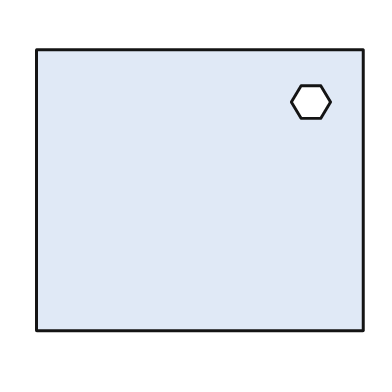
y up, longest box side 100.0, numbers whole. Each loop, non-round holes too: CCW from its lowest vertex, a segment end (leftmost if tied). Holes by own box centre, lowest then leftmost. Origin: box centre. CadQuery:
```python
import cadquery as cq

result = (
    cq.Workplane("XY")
    .moveTo(-50.0, -43.0)
    .lineTo(50.0, -43.0)
    .lineTo(50.0, 43.0)
    .lineTo(-50.0, 43.0)
    .close()
    .moveTo(31.0, 22.0)
    .lineTo(37.0, 22.0)
    .lineTo(40.0, 27.0)
    .lineTo(37.0, 32.0)
    .lineTo(31.0, 32.0)
    .lineTo(28.0, 27.0)
    .close()
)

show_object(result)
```